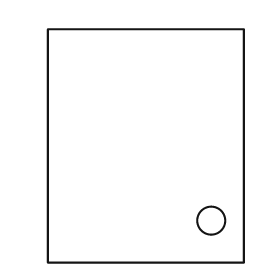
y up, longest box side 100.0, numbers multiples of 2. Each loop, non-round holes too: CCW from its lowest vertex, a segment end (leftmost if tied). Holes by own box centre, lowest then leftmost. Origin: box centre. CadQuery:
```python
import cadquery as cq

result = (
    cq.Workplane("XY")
    .moveTo(-42.0, -50.0)
    .lineTo(42.0, -50.0)
    .lineTo(42.0, 50.0)
    .lineTo(-42.0, 50.0)
    .close()
    .moveTo(28.0, -32.0)
    .circle(6.0)
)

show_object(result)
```